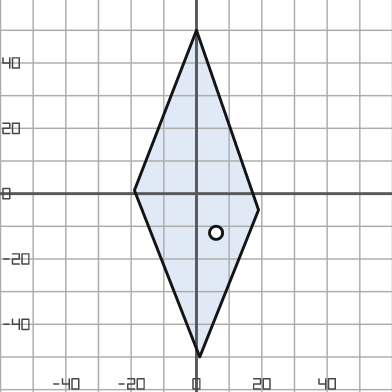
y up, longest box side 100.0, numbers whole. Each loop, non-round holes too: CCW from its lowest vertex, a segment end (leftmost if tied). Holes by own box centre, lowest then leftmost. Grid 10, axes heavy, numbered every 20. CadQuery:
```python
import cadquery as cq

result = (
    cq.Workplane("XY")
    .moveTo(1.0, -50.0)
    .lineTo(19.0, -5.0)
    .lineTo(0.0, 50.0)
    .lineTo(-19.0, 1.0)
    .close()
    .moveTo(6.0, -12.0)
    .circle(2.0)
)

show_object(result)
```